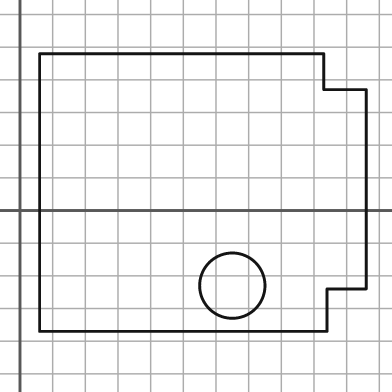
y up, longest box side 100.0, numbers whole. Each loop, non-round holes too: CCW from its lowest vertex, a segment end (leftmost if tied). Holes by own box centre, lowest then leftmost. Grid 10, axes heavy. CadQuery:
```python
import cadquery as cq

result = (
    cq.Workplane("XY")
    .moveTo(6.0, -37.0)
    .lineTo(94.0, -37.0)
    .lineTo(94.0, -24.0)
    .lineTo(106.0, -24.0)
    .lineTo(106.0, 37.0)
    .lineTo(93.0, 37.0)
    .lineTo(93.0, 48.0)
    .lineTo(6.0, 48.0)
    .close()
    .moveTo(65.0, -23.0)
    .circle(10.0)
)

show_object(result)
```